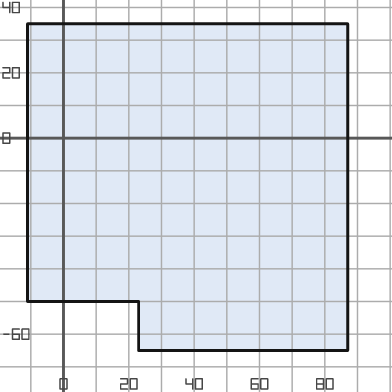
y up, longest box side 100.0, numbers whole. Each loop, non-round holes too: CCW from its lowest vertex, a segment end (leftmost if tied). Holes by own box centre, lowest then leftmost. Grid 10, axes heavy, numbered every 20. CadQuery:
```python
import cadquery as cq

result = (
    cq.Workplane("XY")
    .moveTo(23.0, -65.0)
    .lineTo(87.0, -65.0)
    .lineTo(87.0, 35.0)
    .lineTo(-11.0, 35.0)
    .lineTo(-11.0, -50.0)
    .lineTo(23.0, -50.0)
    .close()
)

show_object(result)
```